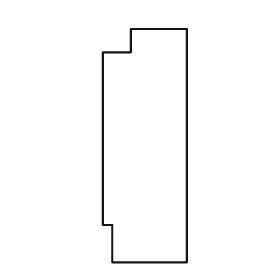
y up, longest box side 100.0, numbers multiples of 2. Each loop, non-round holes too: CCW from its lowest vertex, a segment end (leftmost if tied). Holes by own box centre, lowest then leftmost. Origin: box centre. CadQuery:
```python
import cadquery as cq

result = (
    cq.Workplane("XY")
    .moveTo(-14.0, -50.0)
    .lineTo(18.0, -50.0)
    .lineTo(18.0, 50.0)
    .lineTo(-6.0, 50.0)
    .lineTo(-6.0, 40.0)
    .lineTo(-18.0, 40.0)
    .lineTo(-18.0, -34.0)
    .lineTo(-14.0, -34.0)
    .close()
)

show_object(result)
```